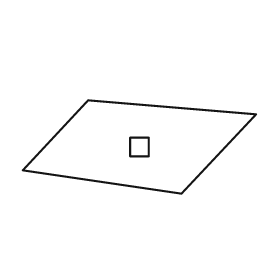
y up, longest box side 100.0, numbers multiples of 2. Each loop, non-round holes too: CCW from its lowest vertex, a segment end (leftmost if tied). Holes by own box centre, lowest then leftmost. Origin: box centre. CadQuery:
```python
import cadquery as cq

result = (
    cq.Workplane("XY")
    .moveTo(18.0, -20.0)
    .lineTo(50.0, 14.0)
    .lineTo(-22.0, 20.0)
    .lineTo(-50.0, -10.0)
    .close()
    .moveTo(-4.0, -4.0)
    .lineTo(4.0, -4.0)
    .lineTo(4.0, 4.0)
    .lineTo(-4.0, 4.0)
    .close()
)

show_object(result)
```